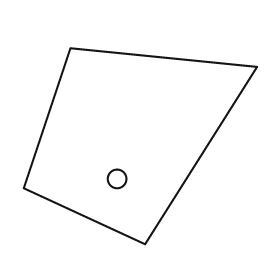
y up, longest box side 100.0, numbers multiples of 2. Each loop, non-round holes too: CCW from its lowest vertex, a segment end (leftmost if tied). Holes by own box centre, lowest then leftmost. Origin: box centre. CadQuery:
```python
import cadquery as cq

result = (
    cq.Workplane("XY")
    .moveTo(2.0, -42.0)
    .lineTo(50.0, 34.0)
    .lineTo(-30.0, 42.0)
    .lineTo(-50.0, -18.0)
    .close()
    .moveTo(-10.0, -14.0)
    .circle(4.0)
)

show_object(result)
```